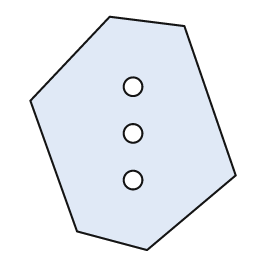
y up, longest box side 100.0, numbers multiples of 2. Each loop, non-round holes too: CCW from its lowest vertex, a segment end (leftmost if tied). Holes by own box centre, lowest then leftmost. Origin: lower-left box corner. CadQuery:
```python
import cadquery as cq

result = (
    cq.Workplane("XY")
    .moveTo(50.0, 0.0)
    .lineTo(88.0, 32.0)
    .lineTo(66.0, 96.0)
    .lineTo(34.0, 100.0)
    .lineTo(0.0, 64.0)
    .lineTo(20.0, 8.0)
    .close()
    .moveTo(44.0, 30.0)
    .circle(4.0)
    .moveTo(44.0, 50.0)
    .circle(4.0)
    .moveTo(44.0, 70.0)
    .circle(4.0)
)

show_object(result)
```